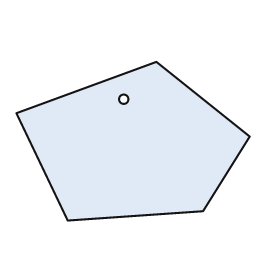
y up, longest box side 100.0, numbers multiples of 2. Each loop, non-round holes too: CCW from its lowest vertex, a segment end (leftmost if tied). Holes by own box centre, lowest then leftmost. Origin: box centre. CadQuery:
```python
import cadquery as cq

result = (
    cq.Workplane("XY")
    .moveTo(-28.0, -34.0)
    .lineTo(30.0, -30.0)
    .lineTo(50.0, 2.0)
    .lineTo(10.0, 34.0)
    .lineTo(-50.0, 12.0)
    .close()
    .moveTo(-4.0, 18.0)
    .circle(2.0)
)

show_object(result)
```